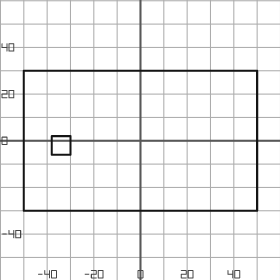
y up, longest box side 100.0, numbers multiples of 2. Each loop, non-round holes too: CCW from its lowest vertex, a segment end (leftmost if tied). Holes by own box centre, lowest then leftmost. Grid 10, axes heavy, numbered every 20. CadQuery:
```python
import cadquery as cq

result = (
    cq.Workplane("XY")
    .moveTo(-50.0, -30.0)
    .lineTo(50.0, -30.0)
    .lineTo(50.0, 30.0)
    .lineTo(-50.0, 30.0)
    .close()
    .moveTo(-38.0, -6.0)
    .lineTo(-30.0, -6.0)
    .lineTo(-30.0, 2.0)
    .lineTo(-38.0, 2.0)
    .close()
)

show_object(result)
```